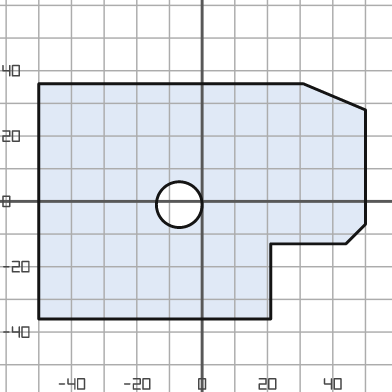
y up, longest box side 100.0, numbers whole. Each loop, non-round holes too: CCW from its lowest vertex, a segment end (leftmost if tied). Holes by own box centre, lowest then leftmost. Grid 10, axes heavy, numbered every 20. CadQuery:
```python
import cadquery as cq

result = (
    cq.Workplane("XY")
    .moveTo(-50.0, -36.0)
    .lineTo(21.0, -36.0)
    .lineTo(21.0, -13.0)
    .lineTo(44.0, -13.0)
    .lineTo(50.0, -7.0)
    .lineTo(50.0, 28.0)
    .lineTo(31.0, 36.0)
    .lineTo(-50.0, 36.0)
    .close()
    .moveTo(-7.0, -1.0)
    .circle(7.0)
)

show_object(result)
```